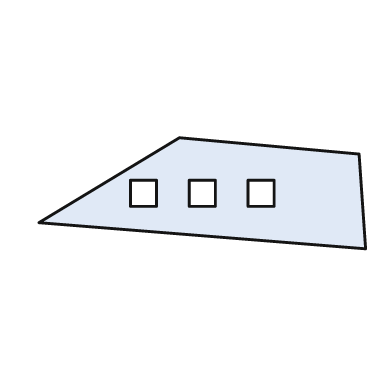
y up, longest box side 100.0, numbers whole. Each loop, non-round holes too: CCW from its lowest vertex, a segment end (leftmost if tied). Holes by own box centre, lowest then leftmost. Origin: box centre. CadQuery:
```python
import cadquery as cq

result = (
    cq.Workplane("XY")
    .moveTo(50.0, -17.0)
    .lineTo(48.0, 12.0)
    .lineTo(-7.0, 17.0)
    .lineTo(-50.0, -9.0)
    .close()
    .moveTo(-22.0, -4.0)
    .lineTo(-14.0, -4.0)
    .lineTo(-14.0, 4.0)
    .lineTo(-22.0, 4.0)
    .close()
    .moveTo(-4.0, -4.0)
    .lineTo(4.0, -4.0)
    .lineTo(4.0, 4.0)
    .lineTo(-4.0, 4.0)
    .close()
    .moveTo(14.0, -4.0)
    .lineTo(22.0, -4.0)
    .lineTo(22.0, 4.0)
    .lineTo(14.0, 4.0)
    .close()
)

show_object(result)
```